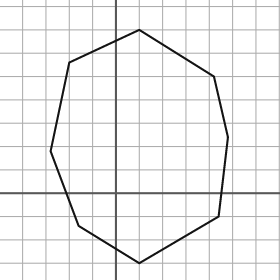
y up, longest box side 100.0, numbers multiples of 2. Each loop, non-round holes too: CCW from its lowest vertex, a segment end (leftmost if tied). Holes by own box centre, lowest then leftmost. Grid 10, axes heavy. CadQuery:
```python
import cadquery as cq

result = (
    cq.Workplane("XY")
    .moveTo(10.0, -30.0)
    .lineTo(44.0, -10.0)
    .lineTo(48.0, 24.0)
    .lineTo(42.0, 50.0)
    .lineTo(10.0, 70.0)
    .lineTo(-20.0, 56.0)
    .lineTo(-28.0, 18.0)
    .lineTo(-16.0, -14.0)
    .close()
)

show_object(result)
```